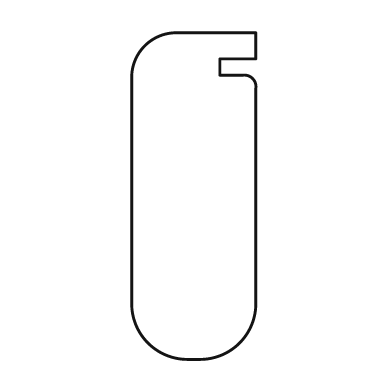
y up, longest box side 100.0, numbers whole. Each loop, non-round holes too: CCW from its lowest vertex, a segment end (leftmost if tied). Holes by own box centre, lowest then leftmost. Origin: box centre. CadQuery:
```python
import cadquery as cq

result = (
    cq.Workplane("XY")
    .moveTo(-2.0, -50.0)
    .lineTo(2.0, -50.0)
    .threePointArc((14.0, -45.0), (19.0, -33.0))
    .lineTo(19.0, 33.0)
    .threePointArc((18.0, 36.0), (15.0, 37.0))
    .lineTo(8.0, 37.0)
    .lineTo(8.0, 42.0)
    .lineTo(19.0, 42.0)
    .lineTo(19.0, 50.0)
    .lineTo(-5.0, 50.0)
    .threePointArc((-15.0, 46.0), (-19.0, 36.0))
    .lineTo(-19.0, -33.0)
    .threePointArc((-14.0, -45.0), (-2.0, -50.0))
    .close()
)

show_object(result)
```